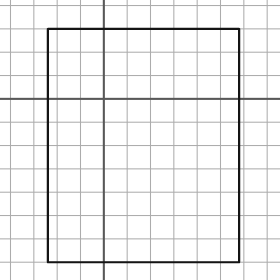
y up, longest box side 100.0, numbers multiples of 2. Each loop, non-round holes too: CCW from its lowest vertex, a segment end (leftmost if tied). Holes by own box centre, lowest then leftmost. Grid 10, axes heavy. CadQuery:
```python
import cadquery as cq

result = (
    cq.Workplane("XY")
    .moveTo(-24.0, -70.0)
    .lineTo(58.0, -70.0)
    .lineTo(58.0, 30.0)
    .lineTo(-24.0, 30.0)
    .close()
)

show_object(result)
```